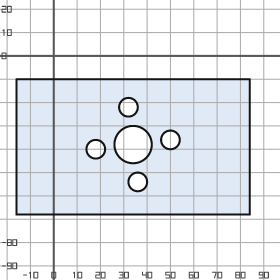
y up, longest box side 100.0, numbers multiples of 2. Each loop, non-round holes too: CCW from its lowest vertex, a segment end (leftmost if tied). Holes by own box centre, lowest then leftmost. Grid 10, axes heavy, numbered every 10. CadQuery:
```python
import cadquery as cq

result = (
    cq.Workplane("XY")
    .moveTo(-16.0, -68.0)
    .lineTo(84.0, -68.0)
    .lineTo(84.0, -10.0)
    .lineTo(-16.0, -10.0)
    .close()
    .moveTo(36.0, -54.0)
    .circle(4.0)
    .moveTo(18.0, -40.0)
    .circle(4.0)
    .moveTo(34.0, -38.0)
    .circle(8.0)
    .moveTo(50.0, -36.0)
    .circle(4.0)
    .moveTo(32.0, -22.0)
    .circle(4.0)
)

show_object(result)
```